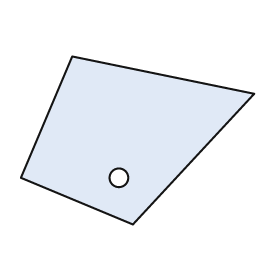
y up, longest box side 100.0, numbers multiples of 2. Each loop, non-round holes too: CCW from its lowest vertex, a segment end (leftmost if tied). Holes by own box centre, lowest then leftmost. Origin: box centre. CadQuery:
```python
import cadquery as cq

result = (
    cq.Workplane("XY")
    .moveTo(-2.0, -36.0)
    .lineTo(50.0, 20.0)
    .lineTo(-28.0, 36.0)
    .lineTo(-50.0, -16.0)
    .close()
    .moveTo(-8.0, -16.0)
    .circle(4.0)
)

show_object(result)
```